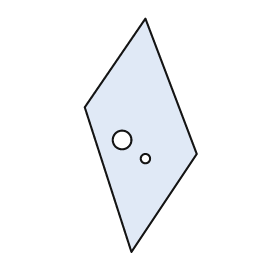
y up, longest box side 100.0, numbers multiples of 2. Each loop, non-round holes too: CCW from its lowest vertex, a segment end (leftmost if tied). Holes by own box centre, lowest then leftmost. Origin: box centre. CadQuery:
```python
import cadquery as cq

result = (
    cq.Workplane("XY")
    .moveTo(-4.0, -50.0)
    .lineTo(24.0, -8.0)
    .lineTo(2.0, 50.0)
    .lineTo(-24.0, 12.0)
    .close()
    .moveTo(2.0, -10.0)
    .circle(2.0)
    .moveTo(-8.0, -2.0)
    .circle(4.0)
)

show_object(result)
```